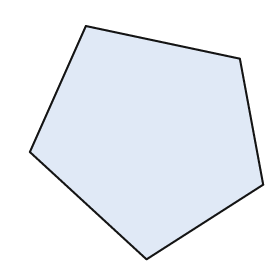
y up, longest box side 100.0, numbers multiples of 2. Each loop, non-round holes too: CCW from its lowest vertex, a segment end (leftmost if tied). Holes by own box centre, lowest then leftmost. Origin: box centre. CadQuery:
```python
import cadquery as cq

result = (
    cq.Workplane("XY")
    .moveTo(0.0, -50.0)
    .lineTo(50.0, -18.0)
    .lineTo(40.0, 36.0)
    .lineTo(-26.0, 50.0)
    .lineTo(-50.0, -4.0)
    .close()
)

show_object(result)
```